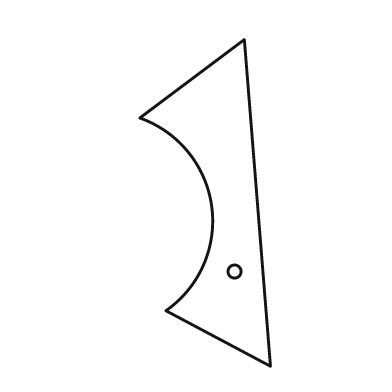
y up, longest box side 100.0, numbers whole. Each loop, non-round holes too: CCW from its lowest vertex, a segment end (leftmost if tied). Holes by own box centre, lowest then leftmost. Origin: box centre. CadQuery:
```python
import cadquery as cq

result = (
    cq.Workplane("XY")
    .moveTo(20.0, -50.0)
    .lineTo(12.0, 50.0)
    .lineTo(-20.0, 26.0)
    .threePointArc((2.0, -1.0), (-12.0, -33.0))
    .close()
    .moveTo(9.0, -21.0)
    .circle(2.0)
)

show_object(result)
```